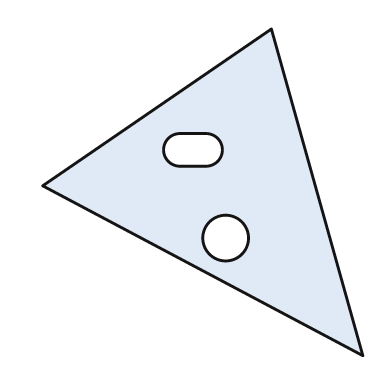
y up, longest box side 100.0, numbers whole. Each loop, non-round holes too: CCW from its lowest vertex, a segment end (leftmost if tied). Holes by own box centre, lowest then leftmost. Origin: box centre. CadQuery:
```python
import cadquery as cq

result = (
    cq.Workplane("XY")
    .moveTo(49.0, -50.0)
    .lineTo(21.0, 50.0)
    .lineTo(-49.0, 2.0)
    .close()
    .moveTo(7.0, -14.0)
    .circle(7.0)
    .moveTo(-7.0, 8.0)
    .lineTo(1.0, 8.0)
    .threePointArc((6.0, 13.0), (1.0, 18.0))
    .lineTo(-7.0, 18.0)
    .threePointArc((-12.0, 13.0), (-7.0, 8.0))
    .close()
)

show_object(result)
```